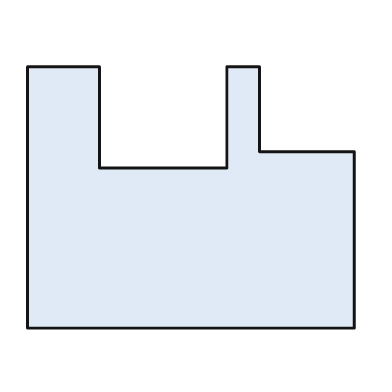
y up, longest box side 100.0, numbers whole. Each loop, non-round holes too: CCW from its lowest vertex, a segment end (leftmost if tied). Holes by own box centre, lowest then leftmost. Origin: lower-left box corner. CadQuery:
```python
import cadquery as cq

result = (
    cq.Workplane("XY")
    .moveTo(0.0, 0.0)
    .lineTo(100.0, 0.0)
    .lineTo(100.0, 54.0)
    .lineTo(71.0, 54.0)
    .lineTo(71.0, 80.0)
    .lineTo(61.0, 80.0)
    .lineTo(61.0, 49.0)
    .lineTo(22.0, 49.0)
    .lineTo(22.0, 80.0)
    .lineTo(0.0, 80.0)
    .close()
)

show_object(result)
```